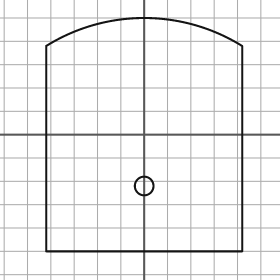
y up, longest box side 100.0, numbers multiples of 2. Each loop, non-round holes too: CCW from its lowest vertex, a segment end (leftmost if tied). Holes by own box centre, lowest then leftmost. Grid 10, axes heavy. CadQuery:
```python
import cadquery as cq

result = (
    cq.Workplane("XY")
    .moveTo(-42.0, -50.0)
    .lineTo(42.0, -50.0)
    .lineTo(42.0, 38.0)
    .threePointArc((0.0, 50.0), (-42.0, 38.0))
    .close()
    .moveTo(0.0, -22.0)
    .circle(4.0)
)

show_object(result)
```